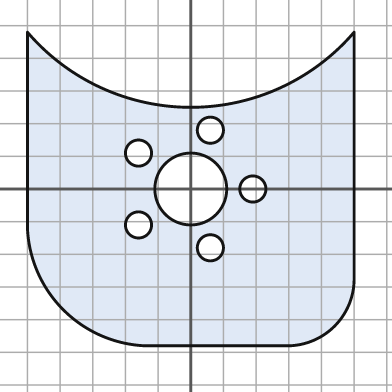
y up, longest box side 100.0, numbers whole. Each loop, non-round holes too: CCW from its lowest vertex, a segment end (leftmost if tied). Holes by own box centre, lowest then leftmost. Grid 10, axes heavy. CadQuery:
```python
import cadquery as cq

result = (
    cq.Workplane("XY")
    .moveTo(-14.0, -48.0)
    .lineTo(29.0, -48.0)
    .threePointArc((44.0, -42.0), (50.0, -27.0))
    .lineTo(50.0, 48.0)
    .threePointArc((0.0, 25.0), (-50.0, 48.0))
    .lineTo(-50.0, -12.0)
    .threePointArc((-39.0, -37.0), (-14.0, -48.0))
    .close()
    .moveTo(6.0, -18.0)
    .circle(4.0)
    .moveTo(-16.0, -11.0)
    .circle(4.0)
    .moveTo(0.0, 0.0)
    .circle(11.0)
    .moveTo(19.0, 0.0)
    .circle(4.0)
    .moveTo(-16.0, 11.0)
    .circle(4.0)
    .moveTo(6.0, 18.0)
    .circle(4.0)
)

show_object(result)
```